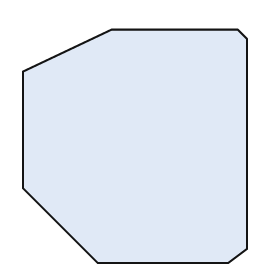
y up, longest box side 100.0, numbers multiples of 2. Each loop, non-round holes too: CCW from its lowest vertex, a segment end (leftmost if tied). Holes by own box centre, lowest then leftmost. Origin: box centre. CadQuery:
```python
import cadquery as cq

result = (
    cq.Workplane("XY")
    .moveTo(-16.0, -50.0)
    .lineTo(40.0, -50.0)
    .lineTo(48.0, -44.0)
    .lineTo(48.0, 46.0)
    .lineTo(44.0, 50.0)
    .lineTo(-10.0, 50.0)
    .lineTo(-48.0, 32.0)
    .lineTo(-48.0, -18.0)
    .close()
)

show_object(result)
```